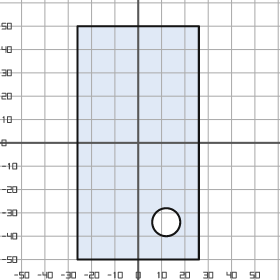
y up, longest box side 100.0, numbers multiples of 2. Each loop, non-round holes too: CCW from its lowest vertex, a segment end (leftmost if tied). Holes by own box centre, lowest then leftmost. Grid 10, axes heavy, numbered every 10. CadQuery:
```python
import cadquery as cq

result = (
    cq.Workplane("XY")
    .moveTo(-26.0, -50.0)
    .lineTo(26.0, -50.0)
    .lineTo(26.0, 50.0)
    .lineTo(-26.0, 50.0)
    .close()
    .moveTo(12.0, -34.0)
    .circle(6.0)
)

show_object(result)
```